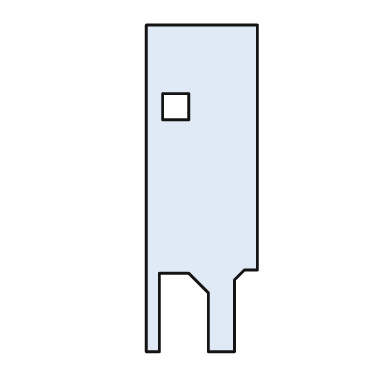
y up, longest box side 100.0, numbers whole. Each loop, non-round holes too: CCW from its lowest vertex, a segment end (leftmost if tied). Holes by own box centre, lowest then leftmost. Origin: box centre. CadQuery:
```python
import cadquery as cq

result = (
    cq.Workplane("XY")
    .moveTo(-17.0, -50.0)
    .lineTo(-13.0, -50.0)
    .lineTo(-13.0, -26.0)
    .lineTo(-4.0, -26.0)
    .lineTo(2.0, -32.0)
    .lineTo(2.0, -50.0)
    .lineTo(10.0, -50.0)
    .lineTo(10.0, -28.0)
    .lineTo(13.0, -25.0)
    .lineTo(17.0, -25.0)
    .lineTo(17.0, 50.0)
    .lineTo(-17.0, 50.0)
    .close()
    .moveTo(-12.0, 21.0)
    .lineTo(-4.0, 21.0)
    .lineTo(-4.0, 29.0)
    .lineTo(-12.0, 29.0)
    .close()
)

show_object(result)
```